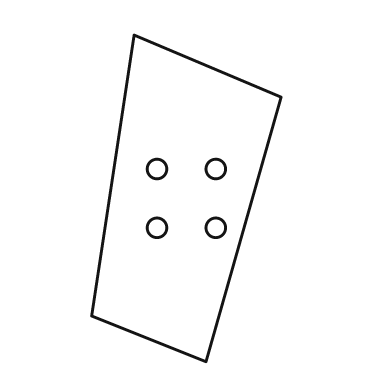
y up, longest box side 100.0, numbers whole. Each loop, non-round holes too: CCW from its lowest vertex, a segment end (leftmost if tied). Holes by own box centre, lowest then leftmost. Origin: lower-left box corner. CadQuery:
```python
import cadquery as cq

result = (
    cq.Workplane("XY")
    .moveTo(35.0, 0.0)
    .lineTo(58.0, 81.0)
    .lineTo(13.0, 100.0)
    .lineTo(0.0, 14.0)
    .close()
    .moveTo(20.0, 41.0)
    .circle(3.0)
    .moveTo(38.0, 41.0)
    .circle(3.0)
    .moveTo(20.0, 59.0)
    .circle(3.0)
    .moveTo(38.0, 59.0)
    .circle(3.0)
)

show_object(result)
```